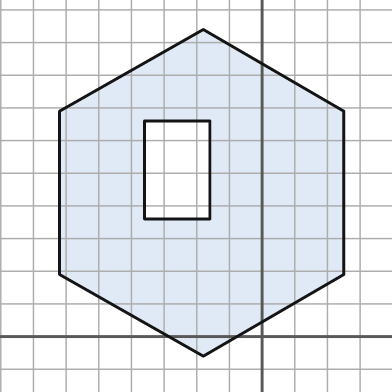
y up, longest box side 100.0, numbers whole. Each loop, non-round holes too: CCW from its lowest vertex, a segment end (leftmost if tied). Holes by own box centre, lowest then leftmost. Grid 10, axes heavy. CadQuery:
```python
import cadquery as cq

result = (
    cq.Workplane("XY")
    .moveTo(-18.0, -6.0)
    .lineTo(25.0, 19.0)
    .lineTo(25.0, 69.0)
    .lineTo(-18.0, 94.0)
    .lineTo(-62.0, 69.0)
    .lineTo(-62.0, 19.0)
    .close()
    .moveTo(-36.0, 36.0)
    .lineTo(-16.0, 36.0)
    .lineTo(-16.0, 66.0)
    .lineTo(-36.0, 66.0)
    .close()
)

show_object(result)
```